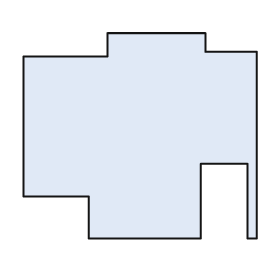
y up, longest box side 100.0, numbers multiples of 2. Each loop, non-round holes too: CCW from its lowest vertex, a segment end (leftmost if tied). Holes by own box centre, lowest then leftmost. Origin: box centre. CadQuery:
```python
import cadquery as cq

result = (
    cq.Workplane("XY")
    .moveTo(-22.0, -44.0)
    .lineTo(26.0, -44.0)
    .lineTo(26.0, -12.0)
    .lineTo(46.0, -12.0)
    .lineTo(46.0, -44.0)
    .lineTo(50.0, -44.0)
    .lineTo(50.0, 36.0)
    .lineTo(28.0, 36.0)
    .lineTo(28.0, 44.0)
    .lineTo(-14.0, 44.0)
    .lineTo(-14.0, 34.0)
    .lineTo(-50.0, 34.0)
    .lineTo(-50.0, -26.0)
    .lineTo(-22.0, -26.0)
    .close()
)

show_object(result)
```